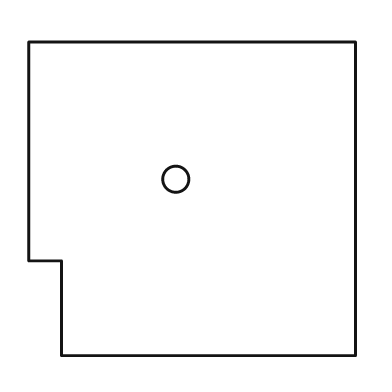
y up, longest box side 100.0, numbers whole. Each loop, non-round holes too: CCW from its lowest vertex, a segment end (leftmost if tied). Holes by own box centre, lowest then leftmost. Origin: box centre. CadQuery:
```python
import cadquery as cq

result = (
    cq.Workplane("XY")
    .moveTo(-40.0, -48.0)
    .lineTo(50.0, -48.0)
    .lineTo(50.0, 48.0)
    .lineTo(-50.0, 48.0)
    .lineTo(-50.0, -19.0)
    .lineTo(-40.0, -19.0)
    .close()
    .moveTo(-5.0, 6.0)
    .circle(4.0)
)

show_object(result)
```